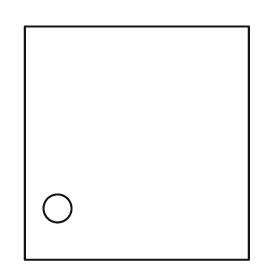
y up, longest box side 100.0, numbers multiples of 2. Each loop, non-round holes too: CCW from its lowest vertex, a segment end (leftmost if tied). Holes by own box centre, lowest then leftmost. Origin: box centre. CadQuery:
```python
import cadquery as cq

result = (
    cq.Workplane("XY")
    .moveTo(-48.0, -50.0)
    .lineTo(48.0, -50.0)
    .lineTo(48.0, 50.0)
    .lineTo(-48.0, 50.0)
    .close()
    .moveTo(-34.0, -28.0)
    .circle(6.0)
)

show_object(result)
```